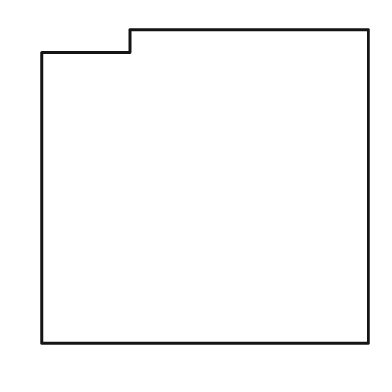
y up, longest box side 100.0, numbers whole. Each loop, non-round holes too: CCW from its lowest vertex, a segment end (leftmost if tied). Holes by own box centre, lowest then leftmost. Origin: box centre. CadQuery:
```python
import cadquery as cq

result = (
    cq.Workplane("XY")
    .moveTo(-50.0, -48.0)
    .lineTo(50.0, -48.0)
    .lineTo(50.0, 48.0)
    .lineTo(-23.0, 48.0)
    .lineTo(-23.0, 41.0)
    .lineTo(-50.0, 41.0)
    .close()
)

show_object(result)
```